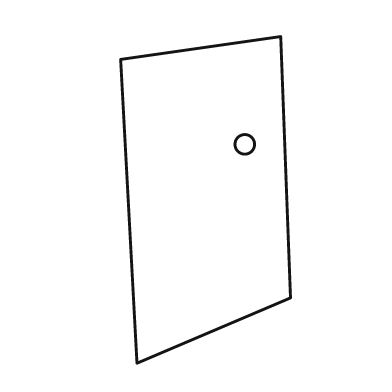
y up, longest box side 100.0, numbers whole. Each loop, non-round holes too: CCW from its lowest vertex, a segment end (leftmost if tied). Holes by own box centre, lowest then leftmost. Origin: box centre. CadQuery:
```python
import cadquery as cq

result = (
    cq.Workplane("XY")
    .moveTo(-21.0, -50.0)
    .lineTo(26.0, -30.0)
    .lineTo(23.0, 50.0)
    .lineTo(-26.0, 43.0)
    .close()
    .moveTo(12.0, 17.0)
    .circle(3.0)
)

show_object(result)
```